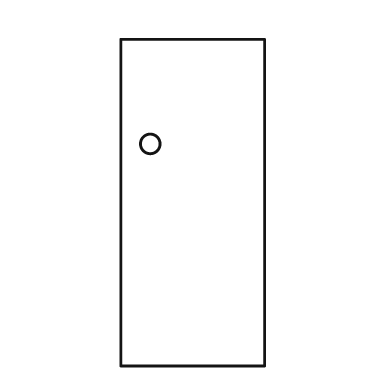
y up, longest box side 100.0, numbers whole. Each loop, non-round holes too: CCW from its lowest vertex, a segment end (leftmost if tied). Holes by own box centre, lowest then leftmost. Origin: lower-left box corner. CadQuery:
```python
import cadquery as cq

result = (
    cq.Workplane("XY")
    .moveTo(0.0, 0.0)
    .lineTo(44.0, 0.0)
    .lineTo(44.0, 100.0)
    .lineTo(0.0, 100.0)
    .close()
    .moveTo(9.0, 68.0)
    .circle(3.0)
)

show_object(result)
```